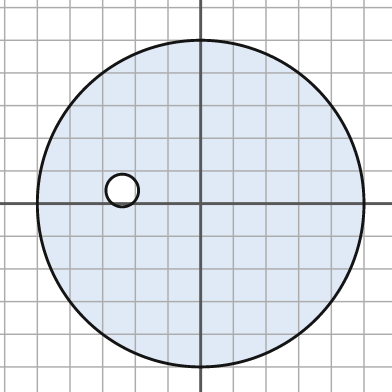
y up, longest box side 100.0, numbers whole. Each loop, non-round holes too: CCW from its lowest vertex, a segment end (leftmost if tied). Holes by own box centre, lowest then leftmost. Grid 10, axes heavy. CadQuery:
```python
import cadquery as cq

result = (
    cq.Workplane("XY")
    .moveTo(0.0, 0.0)
    .circle(50.0)
    .moveTo(-24.0, 4.0)
    .circle(5.0)
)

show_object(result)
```